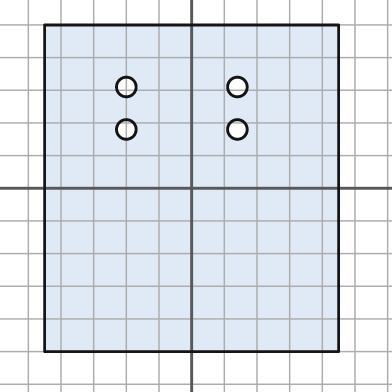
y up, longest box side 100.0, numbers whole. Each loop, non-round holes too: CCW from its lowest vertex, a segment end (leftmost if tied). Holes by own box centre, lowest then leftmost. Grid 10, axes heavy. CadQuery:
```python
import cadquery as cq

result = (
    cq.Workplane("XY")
    .moveTo(-45.0, -50.0)
    .lineTo(45.0, -50.0)
    .lineTo(45.0, 50.0)
    .lineTo(-45.0, 50.0)
    .close()
    .moveTo(-20.0, 18.0)
    .circle(3.0)
    .moveTo(14.0, 18.0)
    .circle(3.0)
    .moveTo(-20.0, 31.0)
    .circle(3.0)
    .moveTo(14.0, 31.0)
    .circle(3.0)
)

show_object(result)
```